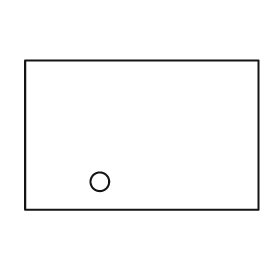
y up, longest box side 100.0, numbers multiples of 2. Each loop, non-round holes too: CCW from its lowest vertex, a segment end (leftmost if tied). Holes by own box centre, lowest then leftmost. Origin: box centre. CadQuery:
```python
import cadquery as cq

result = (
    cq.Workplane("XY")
    .moveTo(-50.0, -32.0)
    .lineTo(50.0, -32.0)
    .lineTo(50.0, 32.0)
    .lineTo(-50.0, 32.0)
    .close()
    .moveTo(-18.0, -20.0)
    .circle(4.0)
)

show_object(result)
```